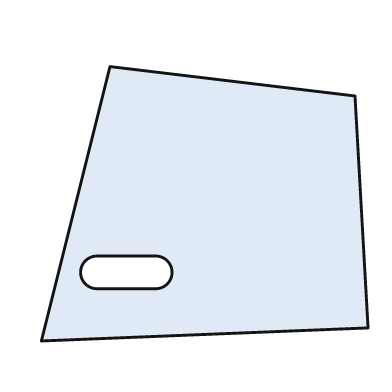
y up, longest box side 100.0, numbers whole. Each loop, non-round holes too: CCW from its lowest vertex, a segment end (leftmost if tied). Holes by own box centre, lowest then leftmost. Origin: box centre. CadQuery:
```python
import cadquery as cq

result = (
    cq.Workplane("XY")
    .moveTo(-50.0, -42.0)
    .lineTo(50.0, -38.0)
    .lineTo(46.0, 33.0)
    .lineTo(-29.0, 42.0)
    .close()
    .moveTo(-33.0, -26.0)
    .lineTo(-15.0, -26.0)
    .threePointArc((-10.0, -21.0), (-15.0, -16.0))
    .lineTo(-33.0, -16.0)
    .threePointArc((-38.0, -21.0), (-33.0, -26.0))
    .close()
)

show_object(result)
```